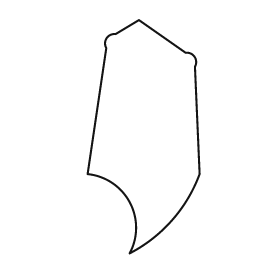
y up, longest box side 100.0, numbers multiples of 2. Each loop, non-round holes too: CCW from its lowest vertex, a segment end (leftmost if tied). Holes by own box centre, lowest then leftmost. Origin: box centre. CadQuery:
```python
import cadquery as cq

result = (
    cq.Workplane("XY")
    .moveTo(-6.0, -50.0)
    .threePointArc((12.0, -36.0), (24.0, -16.0))
    .lineTo(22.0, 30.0)
    .threePointArc((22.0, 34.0), (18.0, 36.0))
    .lineTo(-2.0, 50.0)
    .lineTo(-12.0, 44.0)
    .threePointArc((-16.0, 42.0), (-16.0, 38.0))
    .lineTo(-24.0, -16.0)
    .threePointArc((-6.0, -28.0), (-6.0, -50.0))
    .close()
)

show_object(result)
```